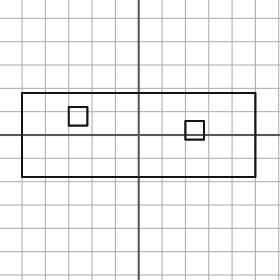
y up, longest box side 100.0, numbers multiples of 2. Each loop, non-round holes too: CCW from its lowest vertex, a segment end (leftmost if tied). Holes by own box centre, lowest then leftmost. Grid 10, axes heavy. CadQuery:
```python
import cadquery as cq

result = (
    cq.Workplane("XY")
    .moveTo(-50.0, -18.0)
    .lineTo(50.0, -18.0)
    .lineTo(50.0, 18.0)
    .lineTo(-50.0, 18.0)
    .close()
    .moveTo(20.0, -2.0)
    .lineTo(28.0, -2.0)
    .lineTo(28.0, 6.0)
    .lineTo(20.0, 6.0)
    .close()
    .moveTo(-30.0, 4.0)
    .lineTo(-22.0, 4.0)
    .lineTo(-22.0, 12.0)
    .lineTo(-30.0, 12.0)
    .close()
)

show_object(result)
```